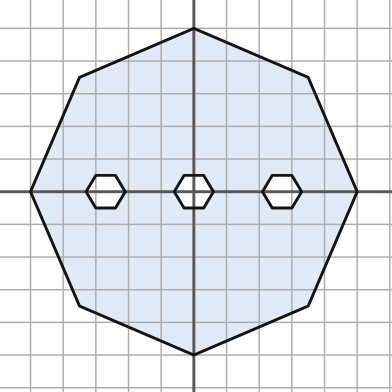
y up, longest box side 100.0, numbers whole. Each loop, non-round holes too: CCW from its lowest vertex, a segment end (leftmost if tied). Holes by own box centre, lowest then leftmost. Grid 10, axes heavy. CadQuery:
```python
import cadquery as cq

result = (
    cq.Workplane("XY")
    .moveTo(0.0, -50.0)
    .lineTo(35.0, -35.0)
    .lineTo(50.0, 0.0)
    .lineTo(35.0, 35.0)
    .lineTo(0.0, 50.0)
    .lineTo(-35.0, 35.0)
    .lineTo(-50.0, 0.0)
    .lineTo(-35.0, -35.0)
    .close()
    .moveTo(-30.0, -5.0)
    .lineTo(-24.0, -5.0)
    .lineTo(-21.0, 0.0)
    .lineTo(-24.0, 5.0)
    .lineTo(-30.0, 5.0)
    .lineTo(-33.0, 0.0)
    .close()
    .moveTo(-3.0, -5.0)
    .lineTo(3.0, -5.0)
    .lineTo(6.0, 0.0)
    .lineTo(3.0, 5.0)
    .lineTo(-3.0, 5.0)
    .lineTo(-6.0, 0.0)
    .close()
    .moveTo(24.0, -5.0)
    .lineTo(30.0, -5.0)
    .lineTo(33.0, 0.0)
    .lineTo(30.0, 5.0)
    .lineTo(24.0, 5.0)
    .lineTo(21.0, 0.0)
    .close()
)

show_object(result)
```